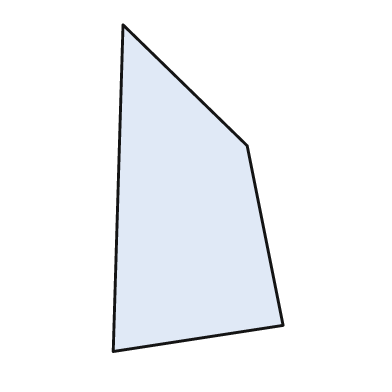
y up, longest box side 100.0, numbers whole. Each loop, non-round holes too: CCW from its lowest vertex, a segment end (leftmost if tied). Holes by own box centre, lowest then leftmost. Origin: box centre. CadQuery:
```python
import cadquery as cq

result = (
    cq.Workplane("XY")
    .moveTo(-26.0, -50.0)
    .lineTo(26.0, -42.0)
    .lineTo(15.0, 13.0)
    .lineTo(-23.0, 50.0)
    .close()
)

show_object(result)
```